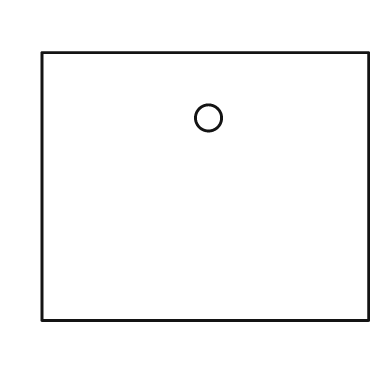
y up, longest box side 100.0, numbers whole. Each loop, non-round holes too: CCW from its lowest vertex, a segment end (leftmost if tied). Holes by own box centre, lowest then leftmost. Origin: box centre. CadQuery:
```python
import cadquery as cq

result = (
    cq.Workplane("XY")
    .moveTo(-50.0, -41.0)
    .lineTo(50.0, -41.0)
    .lineTo(50.0, 41.0)
    .lineTo(-50.0, 41.0)
    .close()
    .moveTo(1.0, 21.0)
    .circle(4.0)
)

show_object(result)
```